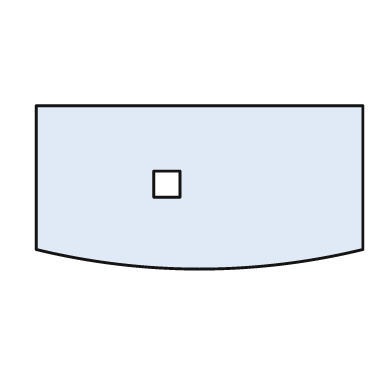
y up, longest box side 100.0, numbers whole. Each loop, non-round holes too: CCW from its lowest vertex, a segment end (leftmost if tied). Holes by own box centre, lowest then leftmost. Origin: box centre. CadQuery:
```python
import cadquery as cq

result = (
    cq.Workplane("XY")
    .moveTo(-50.0, -19.0)
    .threePointArc((0.0, -25.0), (50.0, -19.0))
    .lineTo(50.0, 25.0)
    .lineTo(-50.0, 25.0)
    .close()
    .moveTo(-14.0, -3.0)
    .lineTo(-6.0, -3.0)
    .lineTo(-6.0, 5.0)
    .lineTo(-14.0, 5.0)
    .close()
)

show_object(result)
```